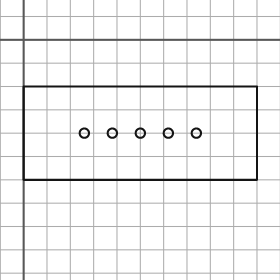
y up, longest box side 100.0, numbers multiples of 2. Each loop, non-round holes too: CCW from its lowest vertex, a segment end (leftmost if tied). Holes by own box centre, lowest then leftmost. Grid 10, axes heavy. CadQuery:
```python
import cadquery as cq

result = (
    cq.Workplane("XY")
    .moveTo(0.0, -60.0)
    .lineTo(100.0, -60.0)
    .lineTo(100.0, -20.0)
    .lineTo(0.0, -20.0)
    .close()
    .moveTo(26.0, -40.0)
    .circle(2.0)
    .moveTo(38.0, -40.0)
    .circle(2.0)
    .moveTo(50.0, -40.0)
    .circle(2.0)
    .moveTo(62.0, -40.0)
    .circle(2.0)
    .moveTo(74.0, -40.0)
    .circle(2.0)
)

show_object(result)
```